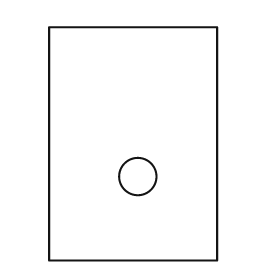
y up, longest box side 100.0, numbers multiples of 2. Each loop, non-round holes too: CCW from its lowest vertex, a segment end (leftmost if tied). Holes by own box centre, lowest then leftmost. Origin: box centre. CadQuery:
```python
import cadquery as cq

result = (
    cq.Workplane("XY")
    .moveTo(-36.0, -50.0)
    .lineTo(36.0, -50.0)
    .lineTo(36.0, 50.0)
    .lineTo(-36.0, 50.0)
    .close()
    .moveTo(2.0, -14.0)
    .circle(8.0)
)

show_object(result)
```